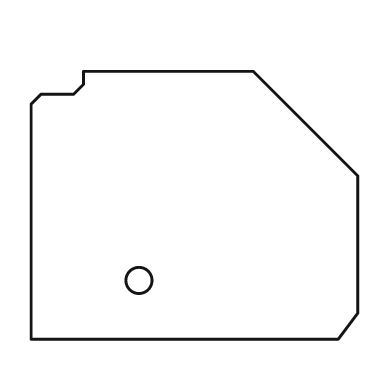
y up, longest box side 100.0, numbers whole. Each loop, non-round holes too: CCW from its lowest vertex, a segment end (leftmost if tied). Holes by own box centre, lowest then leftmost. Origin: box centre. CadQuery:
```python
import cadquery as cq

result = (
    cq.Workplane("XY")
    .moveTo(-50.0, -41.0)
    .lineTo(44.0, -41.0)
    .lineTo(50.0, -33.0)
    .lineTo(50.0, 9.0)
    .lineTo(18.0, 41.0)
    .lineTo(-34.0, 41.0)
    .lineTo(-34.0, 37.0)
    .lineTo(-37.0, 34.0)
    .lineTo(-47.0, 34.0)
    .lineTo(-50.0, 31.0)
    .close()
    .moveTo(-17.0, -23.0)
    .circle(4.0)
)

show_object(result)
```